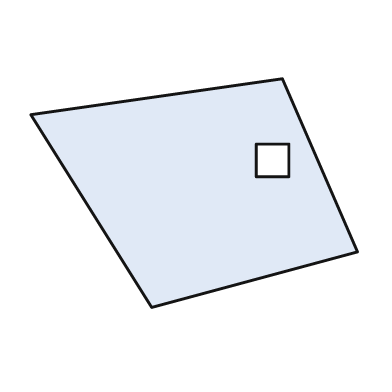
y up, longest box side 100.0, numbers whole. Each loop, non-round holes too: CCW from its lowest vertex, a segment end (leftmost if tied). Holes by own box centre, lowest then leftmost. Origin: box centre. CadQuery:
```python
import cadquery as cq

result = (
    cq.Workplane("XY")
    .moveTo(-13.0, -35.0)
    .lineTo(50.0, -18.0)
    .lineTo(27.0, 35.0)
    .lineTo(-50.0, 24.0)
    .close()
    .moveTo(19.0, 5.0)
    .lineTo(29.0, 5.0)
    .lineTo(29.0, 15.0)
    .lineTo(19.0, 15.0)
    .close()
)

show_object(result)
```